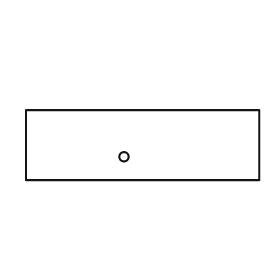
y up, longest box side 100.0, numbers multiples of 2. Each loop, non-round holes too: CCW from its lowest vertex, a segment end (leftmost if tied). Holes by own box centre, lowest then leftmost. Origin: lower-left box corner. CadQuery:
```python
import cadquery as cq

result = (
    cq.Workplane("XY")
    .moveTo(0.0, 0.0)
    .lineTo(100.0, 0.0)
    .lineTo(100.0, 30.0)
    .lineTo(0.0, 30.0)
    .close()
    .moveTo(42.0, 10.0)
    .circle(2.0)
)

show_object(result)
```